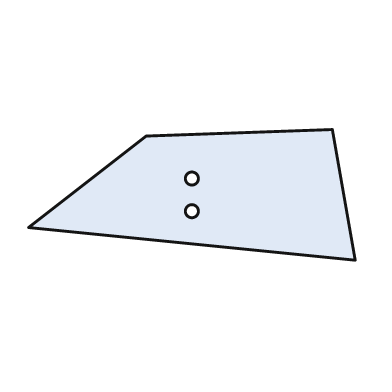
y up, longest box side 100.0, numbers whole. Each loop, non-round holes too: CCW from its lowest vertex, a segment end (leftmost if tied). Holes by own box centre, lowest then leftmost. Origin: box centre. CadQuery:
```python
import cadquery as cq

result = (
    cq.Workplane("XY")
    .moveTo(50.0, -20.0)
    .lineTo(43.0, 20.0)
    .lineTo(-14.0, 18.0)
    .lineTo(-50.0, -10.0)
    .close()
    .moveTo(0.0, -5.0)
    .circle(2.0)
    .moveTo(0.0, 5.0)
    .circle(2.0)
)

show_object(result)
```